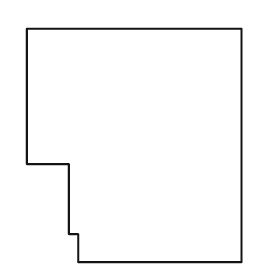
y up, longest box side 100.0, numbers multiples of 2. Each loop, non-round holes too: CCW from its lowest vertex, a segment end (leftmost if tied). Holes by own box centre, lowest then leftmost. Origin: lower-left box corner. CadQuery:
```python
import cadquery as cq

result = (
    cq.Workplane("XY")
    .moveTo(22.0, 0.0)
    .lineTo(92.0, 0.0)
    .lineTo(92.0, 100.0)
    .lineTo(0.0, 100.0)
    .lineTo(0.0, 42.0)
    .lineTo(18.0, 42.0)
    .lineTo(18.0, 12.0)
    .lineTo(22.0, 12.0)
    .close()
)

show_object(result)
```